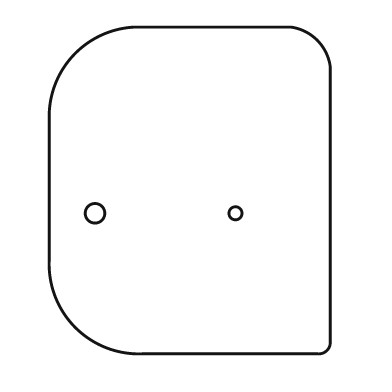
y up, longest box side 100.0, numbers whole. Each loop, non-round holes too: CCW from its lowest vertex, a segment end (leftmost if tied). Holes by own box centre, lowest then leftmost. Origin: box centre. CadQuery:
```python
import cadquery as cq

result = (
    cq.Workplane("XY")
    .moveTo(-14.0, -50.0)
    .lineTo(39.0, -50.0)
    .threePointArc((42.0, -49.0), (43.0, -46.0))
    .lineTo(43.0, 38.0)
    .threePointArc((39.0, 46.0), (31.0, 50.0))
    .lineTo(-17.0, 50.0)
    .threePointArc((-35.0, 42.0), (-43.0, 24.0))
    .lineTo(-43.0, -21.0)
    .threePointArc((-35.0, -42.0), (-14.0, -50.0))
    .close()
    .moveTo(-29.0, -7.0)
    .circle(3.0)
    .moveTo(14.0, -7.0)
    .circle(2.0)
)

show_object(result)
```